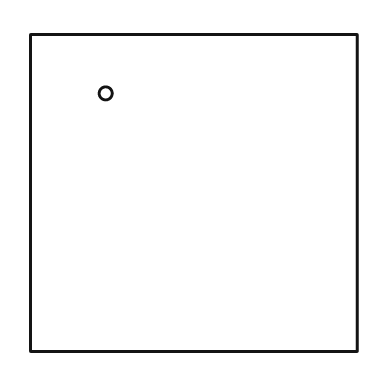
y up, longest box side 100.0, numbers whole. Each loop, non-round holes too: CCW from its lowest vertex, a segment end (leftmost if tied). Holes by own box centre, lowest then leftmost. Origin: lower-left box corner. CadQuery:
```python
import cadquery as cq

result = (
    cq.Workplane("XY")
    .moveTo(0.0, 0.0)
    .lineTo(100.0, 0.0)
    .lineTo(100.0, 97.0)
    .lineTo(0.0, 97.0)
    .close()
    .moveTo(23.0, 79.0)
    .circle(2.0)
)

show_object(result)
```